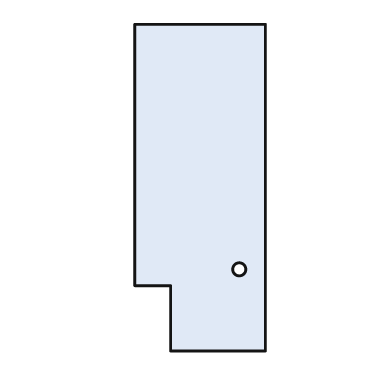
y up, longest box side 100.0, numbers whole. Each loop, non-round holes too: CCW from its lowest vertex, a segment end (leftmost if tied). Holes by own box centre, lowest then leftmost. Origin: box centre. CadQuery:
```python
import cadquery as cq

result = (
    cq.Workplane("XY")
    .moveTo(-9.0, -50.0)
    .lineTo(20.0, -50.0)
    .lineTo(20.0, 50.0)
    .lineTo(-20.0, 50.0)
    .lineTo(-20.0, -30.0)
    .lineTo(-9.0, -30.0)
    .close()
    .moveTo(12.0, -25.0)
    .circle(2.0)
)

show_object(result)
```